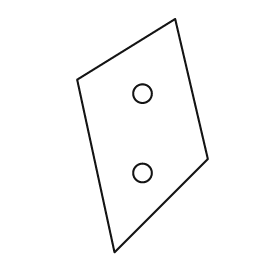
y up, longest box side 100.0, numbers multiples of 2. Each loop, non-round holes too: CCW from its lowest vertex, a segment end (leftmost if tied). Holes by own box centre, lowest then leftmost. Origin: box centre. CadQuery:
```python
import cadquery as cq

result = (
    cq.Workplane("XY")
    .moveTo(-12.0, -50.0)
    .lineTo(28.0, -10.0)
    .lineTo(14.0, 50.0)
    .lineTo(-28.0, 24.0)
    .close()
    .moveTo(0.0, -16.0)
    .circle(4.0)
    .moveTo(0.0, 18.0)
    .circle(4.0)
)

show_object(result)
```